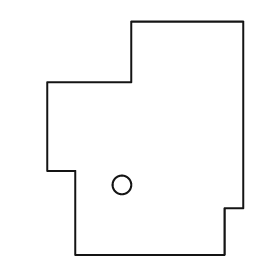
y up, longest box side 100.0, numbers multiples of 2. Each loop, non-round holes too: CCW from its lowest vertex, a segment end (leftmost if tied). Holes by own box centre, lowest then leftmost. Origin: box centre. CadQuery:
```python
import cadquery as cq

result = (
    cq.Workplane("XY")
    .moveTo(-30.0, -50.0)
    .lineTo(34.0, -50.0)
    .lineTo(34.0, -30.0)
    .lineTo(42.0, -30.0)
    .lineTo(42.0, 50.0)
    .lineTo(-6.0, 50.0)
    .lineTo(-6.0, 24.0)
    .lineTo(-42.0, 24.0)
    .lineTo(-42.0, -14.0)
    .lineTo(-30.0, -14.0)
    .close()
    .moveTo(-10.0, -20.0)
    .circle(4.0)
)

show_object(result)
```